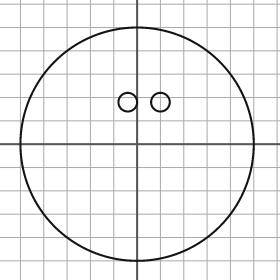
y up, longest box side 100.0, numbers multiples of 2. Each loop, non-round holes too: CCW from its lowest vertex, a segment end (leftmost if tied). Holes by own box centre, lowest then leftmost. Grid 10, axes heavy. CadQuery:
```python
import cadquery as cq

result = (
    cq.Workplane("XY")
    .moveTo(0.0, 0.0)
    .circle(50.0)
    .moveTo(-4.0, 18.0)
    .circle(4.0)
    .moveTo(10.0, 18.0)
    .circle(4.0)
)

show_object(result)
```